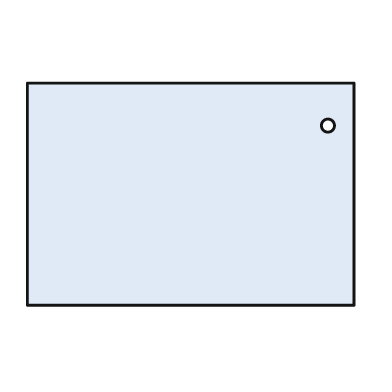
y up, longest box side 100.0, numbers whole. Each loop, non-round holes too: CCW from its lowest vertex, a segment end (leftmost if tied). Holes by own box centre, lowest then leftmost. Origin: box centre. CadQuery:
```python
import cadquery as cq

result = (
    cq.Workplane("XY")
    .moveTo(-50.0, -34.0)
    .lineTo(50.0, -34.0)
    .lineTo(50.0, 34.0)
    .lineTo(-50.0, 34.0)
    .close()
    .moveTo(42.0, 21.0)
    .circle(2.0)
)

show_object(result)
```